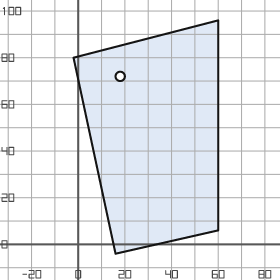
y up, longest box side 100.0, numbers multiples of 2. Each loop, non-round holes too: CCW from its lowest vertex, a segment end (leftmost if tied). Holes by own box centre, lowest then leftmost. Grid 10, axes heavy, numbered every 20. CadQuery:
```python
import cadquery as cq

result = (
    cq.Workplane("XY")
    .moveTo(16.0, -4.0)
    .lineTo(60.0, 6.0)
    .lineTo(60.0, 96.0)
    .lineTo(-2.0, 80.0)
    .close()
    .moveTo(18.0, 72.0)
    .circle(2.0)
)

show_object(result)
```